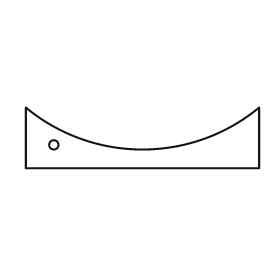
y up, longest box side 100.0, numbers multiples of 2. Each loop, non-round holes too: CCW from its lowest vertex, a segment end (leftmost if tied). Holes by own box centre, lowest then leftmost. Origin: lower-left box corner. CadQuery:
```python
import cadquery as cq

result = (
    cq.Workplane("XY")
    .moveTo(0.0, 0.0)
    .lineTo(100.0, 0.0)
    .lineTo(100.0, 26.0)
    .threePointArc((50.0, 8.0), (0.0, 26.0))
    .close()
    .moveTo(12.0, 10.0)
    .circle(2.0)
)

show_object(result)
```